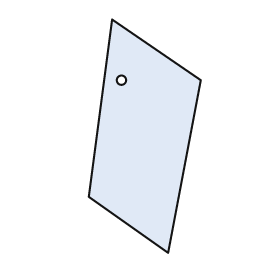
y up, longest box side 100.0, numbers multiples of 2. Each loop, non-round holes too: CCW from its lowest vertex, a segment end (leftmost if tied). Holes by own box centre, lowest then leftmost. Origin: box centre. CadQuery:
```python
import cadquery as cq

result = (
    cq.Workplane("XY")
    .moveTo(10.0, -50.0)
    .lineTo(24.0, 24.0)
    .lineTo(-14.0, 50.0)
    .lineTo(-24.0, -26.0)
    .close()
    .moveTo(-10.0, 24.0)
    .circle(2.0)
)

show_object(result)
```